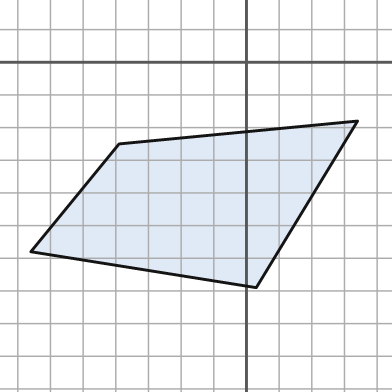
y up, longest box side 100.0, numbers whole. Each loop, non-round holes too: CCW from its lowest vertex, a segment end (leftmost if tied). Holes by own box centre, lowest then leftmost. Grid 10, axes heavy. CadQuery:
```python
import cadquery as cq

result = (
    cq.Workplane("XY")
    .moveTo(3.0, -69.0)
    .lineTo(34.0, -18.0)
    .lineTo(-39.0, -25.0)
    .lineTo(-66.0, -58.0)
    .close()
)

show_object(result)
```